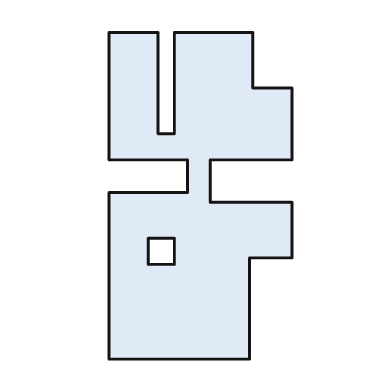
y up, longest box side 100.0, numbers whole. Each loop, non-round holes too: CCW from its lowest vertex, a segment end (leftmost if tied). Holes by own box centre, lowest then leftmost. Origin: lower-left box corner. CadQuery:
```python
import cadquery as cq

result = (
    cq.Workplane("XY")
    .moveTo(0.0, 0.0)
    .lineTo(43.0, 0.0)
    .lineTo(43.0, 31.0)
    .lineTo(56.0, 31.0)
    .lineTo(56.0, 48.0)
    .lineTo(31.0, 48.0)
    .lineTo(31.0, 61.0)
    .lineTo(56.0, 61.0)
    .lineTo(56.0, 83.0)
    .lineTo(44.0, 83.0)
    .lineTo(44.0, 100.0)
    .lineTo(20.0, 100.0)
    .lineTo(20.0, 69.0)
    .lineTo(15.0, 69.0)
    .lineTo(15.0, 100.0)
    .lineTo(0.0, 100.0)
    .lineTo(0.0, 61.0)
    .lineTo(24.0, 61.0)
    .lineTo(24.0, 51.0)
    .lineTo(0.0, 51.0)
    .close()
    .moveTo(12.0, 29.0)
    .lineTo(20.0, 29.0)
    .lineTo(20.0, 37.0)
    .lineTo(12.0, 37.0)
    .close()
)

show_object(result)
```